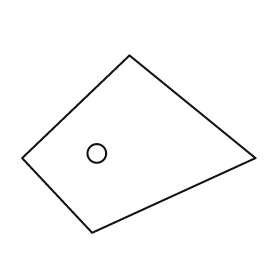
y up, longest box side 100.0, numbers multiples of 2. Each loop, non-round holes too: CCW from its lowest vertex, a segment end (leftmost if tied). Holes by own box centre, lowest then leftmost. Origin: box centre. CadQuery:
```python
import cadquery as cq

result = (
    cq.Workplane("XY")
    .moveTo(-20.0, -38.0)
    .lineTo(50.0, -6.0)
    .lineTo(-4.0, 38.0)
    .lineTo(-50.0, -6.0)
    .close()
    .moveTo(-18.0, -4.0)
    .circle(4.0)
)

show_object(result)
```